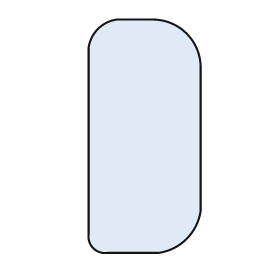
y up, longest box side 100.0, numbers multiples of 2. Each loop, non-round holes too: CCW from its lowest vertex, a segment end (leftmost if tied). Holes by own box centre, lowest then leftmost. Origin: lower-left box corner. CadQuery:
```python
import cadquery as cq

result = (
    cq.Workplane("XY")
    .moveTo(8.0, 0.0)
    .lineTo(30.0, 0.0)
    .threePointArc((42.0, 6.0), (48.0, 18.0))
    .lineTo(48.0, 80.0)
    .threePointArc((42.0, 94.0), (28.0, 100.0))
    .lineTo(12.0, 100.0)
    .threePointArc((4.0, 96.0), (0.0, 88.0))
    .lineTo(0.0, 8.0)
    .threePointArc((2.0, 2.0), (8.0, 0.0))
    .close()
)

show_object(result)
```